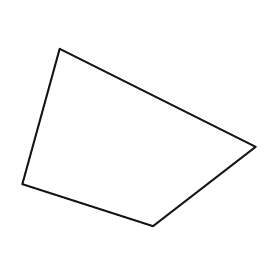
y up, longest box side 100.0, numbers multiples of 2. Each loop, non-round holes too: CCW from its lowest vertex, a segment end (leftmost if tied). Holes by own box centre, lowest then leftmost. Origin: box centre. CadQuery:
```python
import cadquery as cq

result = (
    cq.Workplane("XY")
    .moveTo(6.0, -38.0)
    .lineTo(50.0, -4.0)
    .lineTo(-34.0, 38.0)
    .lineTo(-50.0, -20.0)
    .close()
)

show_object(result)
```